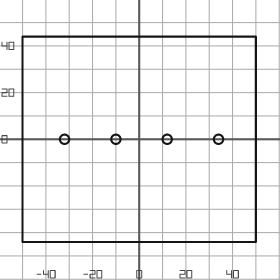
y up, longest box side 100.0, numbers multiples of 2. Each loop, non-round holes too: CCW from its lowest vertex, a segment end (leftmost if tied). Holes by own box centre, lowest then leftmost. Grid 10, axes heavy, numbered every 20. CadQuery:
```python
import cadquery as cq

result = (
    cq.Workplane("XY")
    .moveTo(-50.0, -44.0)
    .lineTo(50.0, -44.0)
    .lineTo(50.0, 44.0)
    .lineTo(-50.0, 44.0)
    .close()
    .moveTo(-32.0, 0.0)
    .circle(2.0)
    .moveTo(-10.0, 0.0)
    .circle(2.0)
    .moveTo(12.0, 0.0)
    .circle(2.0)
    .moveTo(34.0, 0.0)
    .circle(2.0)
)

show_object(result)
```